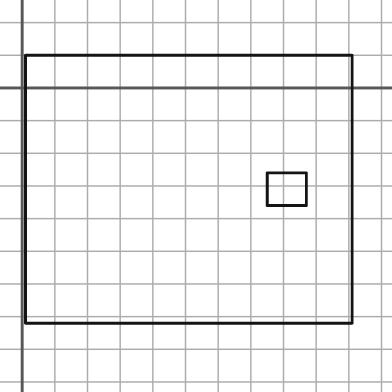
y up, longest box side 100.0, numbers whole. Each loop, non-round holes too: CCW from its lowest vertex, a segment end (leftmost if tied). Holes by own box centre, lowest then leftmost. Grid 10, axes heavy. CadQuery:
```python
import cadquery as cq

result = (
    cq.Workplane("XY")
    .moveTo(1.0, -72.0)
    .lineTo(101.0, -72.0)
    .lineTo(101.0, 10.0)
    .lineTo(1.0, 10.0)
    .close()
    .moveTo(75.0, -36.0)
    .lineTo(87.0, -36.0)
    .lineTo(87.0, -26.0)
    .lineTo(75.0, -26.0)
    .close()
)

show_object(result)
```